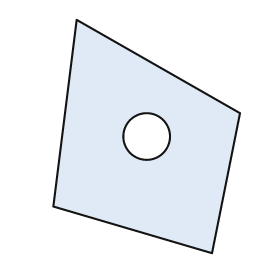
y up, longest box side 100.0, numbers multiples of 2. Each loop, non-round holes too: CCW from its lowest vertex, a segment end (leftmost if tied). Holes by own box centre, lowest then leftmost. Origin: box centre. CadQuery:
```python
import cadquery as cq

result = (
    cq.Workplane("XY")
    .moveTo(28.0, -50.0)
    .lineTo(40.0, 10.0)
    .lineTo(-30.0, 50.0)
    .lineTo(-40.0, -30.0)
    .close()
    .moveTo(0.0, 0.0)
    .circle(10.0)
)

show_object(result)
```